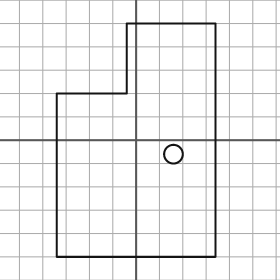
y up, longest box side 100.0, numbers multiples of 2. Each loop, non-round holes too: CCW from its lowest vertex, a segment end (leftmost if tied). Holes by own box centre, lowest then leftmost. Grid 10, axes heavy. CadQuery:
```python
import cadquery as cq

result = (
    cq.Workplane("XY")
    .moveTo(-34.0, -50.0)
    .lineTo(34.0, -50.0)
    .lineTo(34.0, 50.0)
    .lineTo(-4.0, 50.0)
    .lineTo(-4.0, 20.0)
    .lineTo(-34.0, 20.0)
    .close()
    .moveTo(16.0, -6.0)
    .circle(4.0)
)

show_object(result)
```